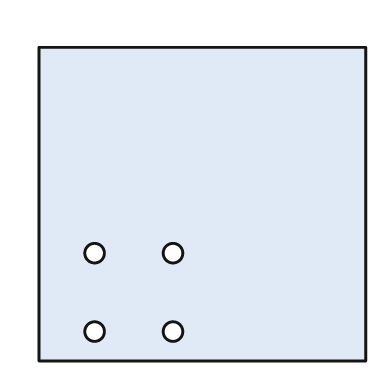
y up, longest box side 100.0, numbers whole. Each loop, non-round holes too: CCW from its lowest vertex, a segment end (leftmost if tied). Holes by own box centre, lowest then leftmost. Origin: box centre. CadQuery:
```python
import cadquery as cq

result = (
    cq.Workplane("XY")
    .moveTo(-50.0, -48.0)
    .lineTo(50.0, -48.0)
    .lineTo(50.0, 48.0)
    .lineTo(-50.0, 48.0)
    .close()
    .moveTo(-33.0, -39.0)
    .circle(3.0)
    .moveTo(-9.0, -39.0)
    .circle(3.0)
    .moveTo(-33.0, -15.0)
    .circle(3.0)
    .moveTo(-9.0, -15.0)
    .circle(3.0)
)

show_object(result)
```